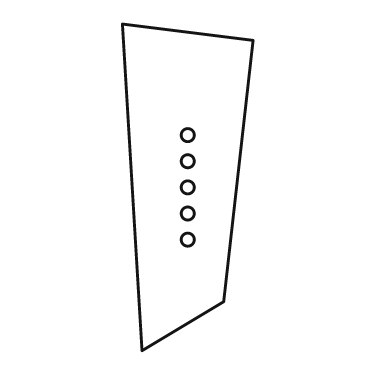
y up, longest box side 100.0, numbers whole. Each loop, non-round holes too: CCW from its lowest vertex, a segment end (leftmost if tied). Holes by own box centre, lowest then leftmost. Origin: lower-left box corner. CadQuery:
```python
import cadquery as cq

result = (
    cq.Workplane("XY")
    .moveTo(6.0, 0.0)
    .lineTo(31.0, 15.0)
    .lineTo(40.0, 95.0)
    .lineTo(0.0, 100.0)
    .close()
    .moveTo(20.0, 34.0)
    .circle(2.0)
    .moveTo(20.0, 42.0)
    .circle(2.0)
    .moveTo(20.0, 50.0)
    .circle(2.0)
    .moveTo(20.0, 58.0)
    .circle(2.0)
    .moveTo(20.0, 66.0)
    .circle(2.0)
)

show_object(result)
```